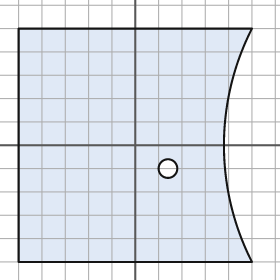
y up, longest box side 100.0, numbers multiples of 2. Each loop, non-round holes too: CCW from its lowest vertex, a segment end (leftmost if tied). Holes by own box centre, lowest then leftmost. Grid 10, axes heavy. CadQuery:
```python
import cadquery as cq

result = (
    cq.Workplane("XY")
    .moveTo(-50.0, -50.0)
    .lineTo(50.0, -50.0)
    .threePointArc((38.0, 0.0), (50.0, 50.0))
    .lineTo(-50.0, 50.0)
    .close()
    .moveTo(14.0, -10.0)
    .circle(4.0)
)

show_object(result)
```